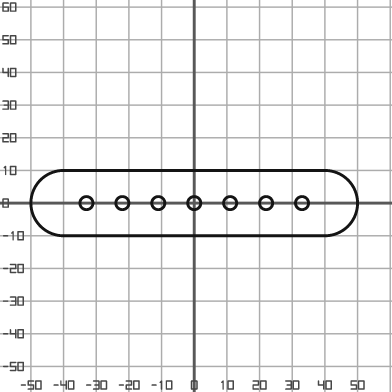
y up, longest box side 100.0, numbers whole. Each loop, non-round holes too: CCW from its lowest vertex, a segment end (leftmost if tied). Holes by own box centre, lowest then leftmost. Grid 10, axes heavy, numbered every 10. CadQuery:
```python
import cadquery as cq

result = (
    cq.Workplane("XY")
    .moveTo(-40.0, -10.0)
    .lineTo(40.0, -10.0)
    .threePointArc((50.0, 0.0), (40.0, 10.0))
    .lineTo(-40.0, 10.0)
    .threePointArc((-50.0, 0.0), (-40.0, -10.0))
    .close()
    .moveTo(-33.0, 0.0)
    .circle(2.0)
    .moveTo(-22.0, 0.0)
    .circle(2.0)
    .moveTo(-11.0, 0.0)
    .circle(2.0)
    .moveTo(0.0, 0.0)
    .circle(2.0)
    .moveTo(11.0, 0.0)
    .circle(2.0)
    .moveTo(22.0, 0.0)
    .circle(2.0)
    .moveTo(33.0, 0.0)
    .circle(2.0)
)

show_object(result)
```